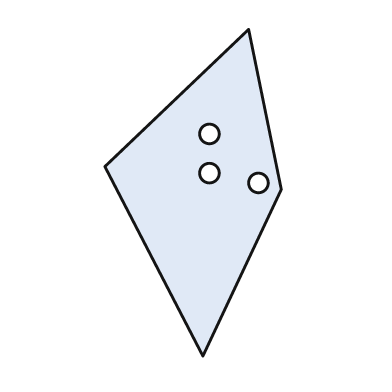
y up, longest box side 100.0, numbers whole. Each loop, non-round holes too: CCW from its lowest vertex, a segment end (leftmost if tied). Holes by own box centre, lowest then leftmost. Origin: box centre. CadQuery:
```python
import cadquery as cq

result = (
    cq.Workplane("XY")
    .moveTo(3.0, -50.0)
    .lineTo(27.0, 1.0)
    .lineTo(17.0, 50.0)
    .lineTo(-27.0, 8.0)
    .close()
    .moveTo(20.0, 3.0)
    .circle(3.0)
    .moveTo(5.0, 6.0)
    .circle(3.0)
    .moveTo(5.0, 18.0)
    .circle(3.0)
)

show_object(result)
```